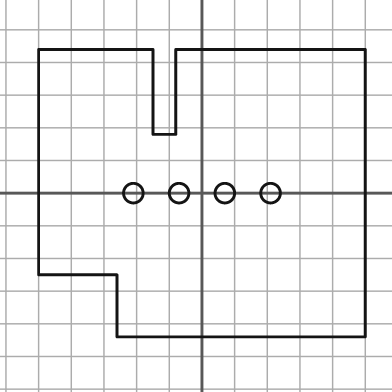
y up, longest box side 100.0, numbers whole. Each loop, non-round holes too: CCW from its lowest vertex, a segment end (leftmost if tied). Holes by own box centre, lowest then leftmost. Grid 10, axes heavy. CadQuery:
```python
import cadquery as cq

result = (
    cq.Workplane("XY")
    .moveTo(-26.0, -44.0)
    .lineTo(50.0, -44.0)
    .lineTo(50.0, 44.0)
    .lineTo(-8.0, 44.0)
    .lineTo(-8.0, 18.0)
    .lineTo(-15.0, 18.0)
    .lineTo(-15.0, 44.0)
    .lineTo(-50.0, 44.0)
    .lineTo(-50.0, -25.0)
    .lineTo(-26.0, -25.0)
    .close()
    .moveTo(-21.0, 0.0)
    .circle(3.0)
    .moveTo(-7.0, 0.0)
    .circle(3.0)
    .moveTo(7.0, 0.0)
    .circle(3.0)
    .moveTo(21.0, 0.0)
    .circle(3.0)
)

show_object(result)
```